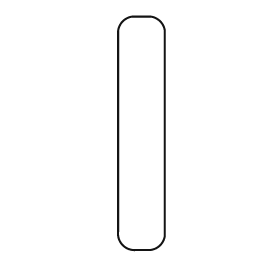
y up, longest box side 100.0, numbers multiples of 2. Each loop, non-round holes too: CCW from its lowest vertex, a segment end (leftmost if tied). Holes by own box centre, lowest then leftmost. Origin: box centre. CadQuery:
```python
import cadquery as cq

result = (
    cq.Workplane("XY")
    .moveTo(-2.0, -50.0)
    .lineTo(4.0, -50.0)
    .threePointArc((8.0, -48.0), (10.0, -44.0))
    .lineTo(10.0, 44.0)
    .threePointArc((8.0, 48.0), (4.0, 50.0))
    .lineTo(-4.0, 50.0)
    .threePointArc((-8.0, 48.0), (-10.0, 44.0))
    .lineTo(-10.0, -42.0)
    .threePointArc((-8.0, -48.0), (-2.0, -50.0))
    .close()
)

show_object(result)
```